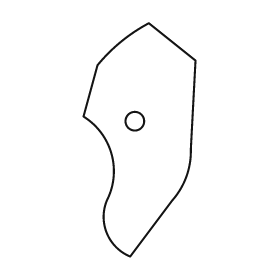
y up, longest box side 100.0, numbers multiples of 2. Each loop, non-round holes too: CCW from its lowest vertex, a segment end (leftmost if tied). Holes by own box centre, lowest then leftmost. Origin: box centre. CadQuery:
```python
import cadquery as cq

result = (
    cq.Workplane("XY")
    .moveTo(-4.0, -50.0)
    .lineTo(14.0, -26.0)
    .threePointArc((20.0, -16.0), (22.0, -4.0))
    .lineTo(24.0, 34.0)
    .lineTo(4.0, 50.0)
    .threePointArc((-8.0, 42.0), (-18.0, 32.0))
    .lineTo(-24.0, 10.0)
    .threePointArc((-12.0, -6.0), (-14.0, -26.0))
    .threePointArc((-14.0, -40.0), (-4.0, -50.0))
    .close()
    .moveTo(-2.0, 8.0)
    .circle(4.0)
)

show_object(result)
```